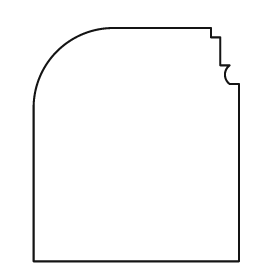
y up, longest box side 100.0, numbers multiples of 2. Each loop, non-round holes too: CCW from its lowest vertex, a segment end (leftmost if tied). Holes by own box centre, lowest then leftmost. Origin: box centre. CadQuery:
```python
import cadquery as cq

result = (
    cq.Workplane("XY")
    .moveTo(-44.0, -50.0)
    .lineTo(44.0, -50.0)
    .lineTo(44.0, 26.0)
    .lineTo(40.0, 26.0)
    .threePointArc((38.0, 30.0), (40.0, 34.0))
    .lineTo(36.0, 34.0)
    .lineTo(36.0, 46.0)
    .lineTo(32.0, 46.0)
    .lineTo(32.0, 50.0)
    .lineTo(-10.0, 50.0)
    .threePointArc((-34.0, 40.0), (-44.0, 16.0))
    .close()
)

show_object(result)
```